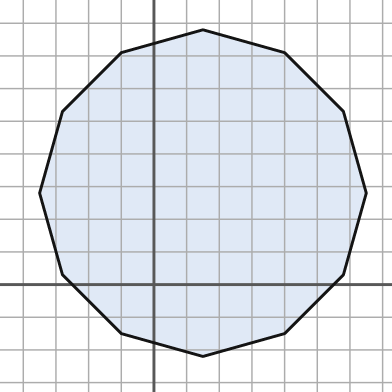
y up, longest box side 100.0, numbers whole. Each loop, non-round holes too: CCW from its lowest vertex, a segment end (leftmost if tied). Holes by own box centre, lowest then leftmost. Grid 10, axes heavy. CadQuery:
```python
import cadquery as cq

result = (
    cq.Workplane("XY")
    .moveTo(15.0, -22.0)
    .lineTo(40.0, -15.0)
    .lineTo(58.0, 3.0)
    .lineTo(65.0, 28.0)
    .lineTo(58.0, 53.0)
    .lineTo(40.0, 71.0)
    .lineTo(15.0, 78.0)
    .lineTo(-10.0, 71.0)
    .lineTo(-28.0, 53.0)
    .lineTo(-35.0, 28.0)
    .lineTo(-28.0, 3.0)
    .lineTo(-10.0, -15.0)
    .close()
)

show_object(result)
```